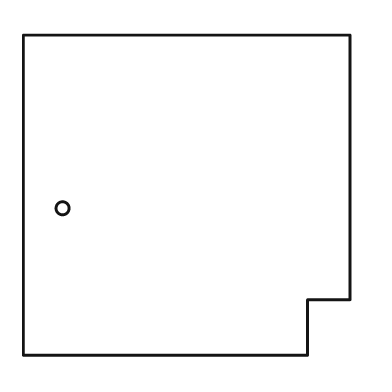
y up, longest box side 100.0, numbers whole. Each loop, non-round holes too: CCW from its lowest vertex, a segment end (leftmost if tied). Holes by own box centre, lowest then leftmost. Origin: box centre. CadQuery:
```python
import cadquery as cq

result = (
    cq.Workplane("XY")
    .moveTo(-50.0, -49.0)
    .lineTo(37.0, -49.0)
    .lineTo(37.0, -32.0)
    .lineTo(50.0, -32.0)
    .lineTo(50.0, 49.0)
    .lineTo(-50.0, 49.0)
    .close()
    .moveTo(-38.0, -4.0)
    .circle(2.0)
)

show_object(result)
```